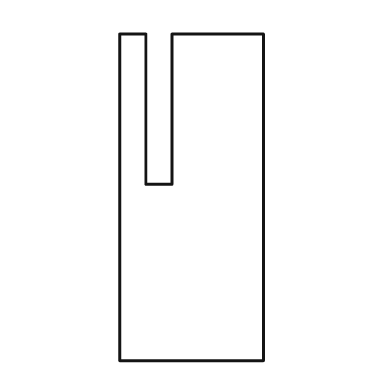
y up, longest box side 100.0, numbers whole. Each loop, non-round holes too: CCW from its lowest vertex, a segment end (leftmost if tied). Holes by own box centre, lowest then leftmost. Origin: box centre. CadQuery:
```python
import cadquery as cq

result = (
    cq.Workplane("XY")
    .moveTo(-22.0, -50.0)
    .lineTo(22.0, -50.0)
    .lineTo(22.0, 50.0)
    .lineTo(-6.0, 50.0)
    .lineTo(-6.0, 4.0)
    .lineTo(-14.0, 4.0)
    .lineTo(-14.0, 50.0)
    .lineTo(-22.0, 50.0)
    .close()
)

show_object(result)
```